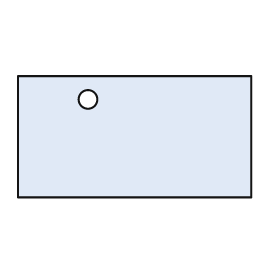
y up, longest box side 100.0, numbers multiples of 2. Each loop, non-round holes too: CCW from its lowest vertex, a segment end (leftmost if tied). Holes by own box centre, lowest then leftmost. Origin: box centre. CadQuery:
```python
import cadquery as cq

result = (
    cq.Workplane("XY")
    .moveTo(-50.0, -26.0)
    .lineTo(50.0, -26.0)
    .lineTo(50.0, 26.0)
    .lineTo(-50.0, 26.0)
    .close()
    .moveTo(-20.0, 16.0)
    .circle(4.0)
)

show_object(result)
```